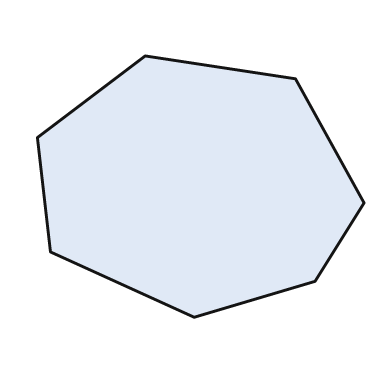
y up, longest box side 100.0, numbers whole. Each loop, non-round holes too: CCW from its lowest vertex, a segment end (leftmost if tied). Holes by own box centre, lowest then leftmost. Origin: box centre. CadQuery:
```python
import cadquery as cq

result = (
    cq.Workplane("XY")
    .moveTo(-2.0, -40.0)
    .lineTo(35.0, -29.0)
    .lineTo(50.0, -5.0)
    .lineTo(29.0, 33.0)
    .lineTo(-17.0, 40.0)
    .lineTo(-50.0, 15.0)
    .lineTo(-46.0, -20.0)
    .close()
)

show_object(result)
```